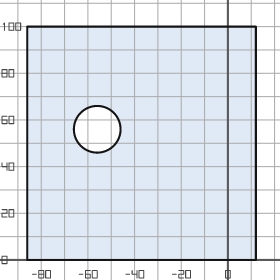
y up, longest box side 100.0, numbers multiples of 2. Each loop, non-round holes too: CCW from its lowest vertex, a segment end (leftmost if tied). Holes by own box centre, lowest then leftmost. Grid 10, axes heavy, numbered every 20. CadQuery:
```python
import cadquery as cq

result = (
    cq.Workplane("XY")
    .moveTo(-86.0, 0.0)
    .lineTo(12.0, 0.0)
    .lineTo(12.0, 100.0)
    .lineTo(-86.0, 100.0)
    .close()
    .moveTo(-56.0, 56.0)
    .circle(10.0)
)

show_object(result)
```